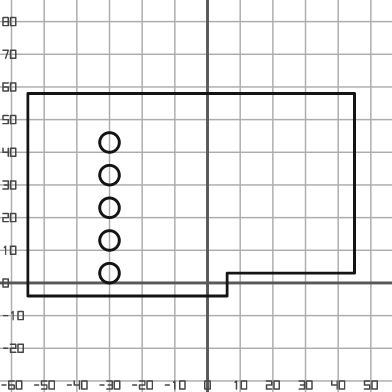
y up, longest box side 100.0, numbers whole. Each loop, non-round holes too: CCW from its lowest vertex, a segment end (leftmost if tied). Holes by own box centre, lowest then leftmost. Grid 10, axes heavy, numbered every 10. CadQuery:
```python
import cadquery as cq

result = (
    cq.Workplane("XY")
    .moveTo(-55.0, -4.0)
    .lineTo(6.0, -4.0)
    .lineTo(6.0, 3.0)
    .lineTo(45.0, 3.0)
    .lineTo(45.0, 58.0)
    .lineTo(-55.0, 58.0)
    .close()
    .moveTo(-30.0, 3.0)
    .circle(3.0)
    .moveTo(-30.0, 13.0)
    .circle(3.0)
    .moveTo(-30.0, 23.0)
    .circle(3.0)
    .moveTo(-30.0, 33.0)
    .circle(3.0)
    .moveTo(-30.0, 43.0)
    .circle(3.0)
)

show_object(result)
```